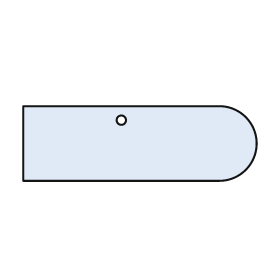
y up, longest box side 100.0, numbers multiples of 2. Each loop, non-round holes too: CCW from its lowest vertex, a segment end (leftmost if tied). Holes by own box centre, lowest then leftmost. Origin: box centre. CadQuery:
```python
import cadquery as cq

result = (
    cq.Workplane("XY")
    .moveTo(-50.0, -16.0)
    .lineTo(34.0, -16.0)
    .threePointArc((50.0, 0.0), (34.0, 16.0))
    .lineTo(-50.0, 16.0)
    .close()
    .moveTo(-8.0, 10.0)
    .circle(2.0)
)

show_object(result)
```